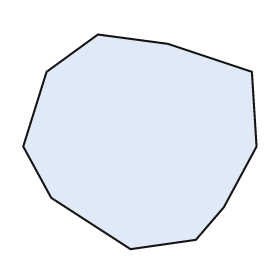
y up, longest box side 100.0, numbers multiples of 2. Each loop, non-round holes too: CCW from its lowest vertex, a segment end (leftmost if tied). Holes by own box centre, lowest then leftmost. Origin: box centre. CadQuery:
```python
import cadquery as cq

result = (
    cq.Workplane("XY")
    .moveTo(-4.0, -46.0)
    .lineTo(24.0, -42.0)
    .lineTo(36.0, -28.0)
    .lineTo(50.0, -2.0)
    .lineTo(48.0, 30.0)
    .lineTo(12.0, 42.0)
    .lineTo(-18.0, 46.0)
    .lineTo(-40.0, 30.0)
    .lineTo(-50.0, -2.0)
    .lineTo(-38.0, -24.0)
    .close()
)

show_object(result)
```